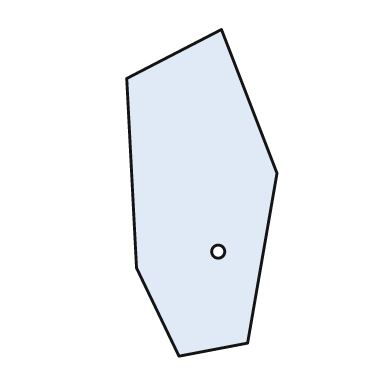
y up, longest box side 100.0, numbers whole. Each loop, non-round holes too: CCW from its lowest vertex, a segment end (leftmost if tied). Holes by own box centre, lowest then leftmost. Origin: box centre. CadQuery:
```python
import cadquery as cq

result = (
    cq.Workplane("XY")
    .moveTo(-7.0, -50.0)
    .lineTo(14.0, -46.0)
    .lineTo(23.0, 6.0)
    .lineTo(6.0, 50.0)
    .lineTo(-23.0, 35.0)
    .lineTo(-20.0, -23.0)
    .close()
    .moveTo(5.0, -18.0)
    .circle(2.0)
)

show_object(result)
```